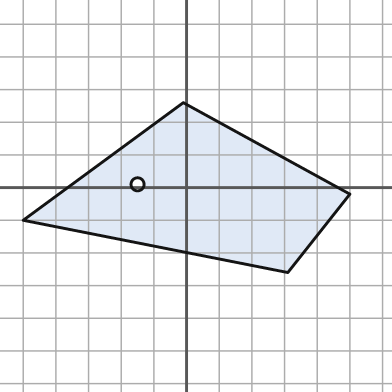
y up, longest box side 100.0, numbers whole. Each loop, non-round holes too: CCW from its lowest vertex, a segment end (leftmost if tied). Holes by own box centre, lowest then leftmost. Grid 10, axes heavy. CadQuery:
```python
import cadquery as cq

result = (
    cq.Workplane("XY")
    .moveTo(31.0, -26.0)
    .lineTo(50.0, -2.0)
    .lineTo(-1.0, 26.0)
    .lineTo(-50.0, -10.0)
    .close()
    .moveTo(-15.0, 1.0)
    .circle(2.0)
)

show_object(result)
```